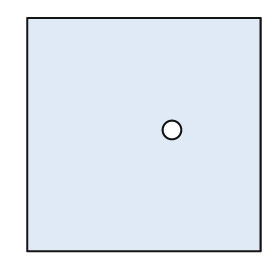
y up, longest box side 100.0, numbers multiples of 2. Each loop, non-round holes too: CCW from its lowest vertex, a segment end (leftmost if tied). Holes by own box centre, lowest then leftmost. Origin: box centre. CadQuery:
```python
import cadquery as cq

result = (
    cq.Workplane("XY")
    .moveTo(-50.0, -50.0)
    .lineTo(50.0, -50.0)
    .lineTo(50.0, 50.0)
    .lineTo(-50.0, 50.0)
    .close()
    .moveTo(12.0, 2.0)
    .circle(4.0)
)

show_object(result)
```